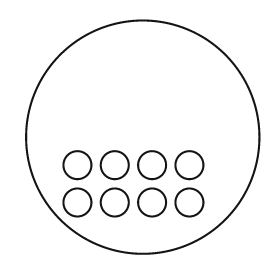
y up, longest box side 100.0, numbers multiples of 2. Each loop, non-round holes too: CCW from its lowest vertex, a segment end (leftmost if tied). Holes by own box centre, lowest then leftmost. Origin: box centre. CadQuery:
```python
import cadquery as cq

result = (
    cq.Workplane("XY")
    .moveTo(0.0, 0.0)
    .circle(50.0)
    .moveTo(-28.0, -28.0)
    .circle(6.0)
    .moveTo(-12.0, -28.0)
    .circle(6.0)
    .moveTo(4.0, -28.0)
    .circle(6.0)
    .moveTo(20.0, -28.0)
    .circle(6.0)
    .moveTo(-28.0, -12.0)
    .circle(6.0)
    .moveTo(-12.0, -12.0)
    .circle(6.0)
    .moveTo(4.0, -12.0)
    .circle(6.0)
    .moveTo(20.0, -12.0)
    .circle(6.0)
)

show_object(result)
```